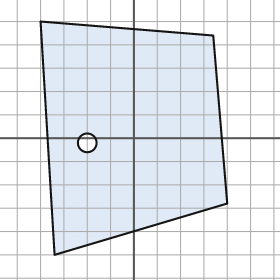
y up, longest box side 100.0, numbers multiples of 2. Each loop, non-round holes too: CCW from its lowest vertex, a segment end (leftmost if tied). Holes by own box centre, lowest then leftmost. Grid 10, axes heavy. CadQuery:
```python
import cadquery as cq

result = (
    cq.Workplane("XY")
    .moveTo(-34.0, -50.0)
    .lineTo(40.0, -28.0)
    .lineTo(34.0, 44.0)
    .lineTo(-40.0, 50.0)
    .close()
    .moveTo(-20.0, -2.0)
    .circle(4.0)
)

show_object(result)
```